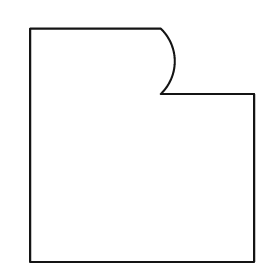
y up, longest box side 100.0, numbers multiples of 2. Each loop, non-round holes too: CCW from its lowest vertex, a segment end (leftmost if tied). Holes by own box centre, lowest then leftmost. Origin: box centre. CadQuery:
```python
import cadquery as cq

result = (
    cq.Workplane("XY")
    .moveTo(-48.0, -50.0)
    .lineTo(48.0, -50.0)
    .lineTo(48.0, 22.0)
    .lineTo(8.0, 22.0)
    .threePointArc((14.0, 36.0), (8.0, 50.0))
    .lineTo(-48.0, 50.0)
    .close()
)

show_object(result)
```